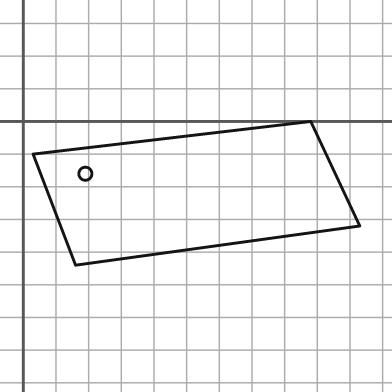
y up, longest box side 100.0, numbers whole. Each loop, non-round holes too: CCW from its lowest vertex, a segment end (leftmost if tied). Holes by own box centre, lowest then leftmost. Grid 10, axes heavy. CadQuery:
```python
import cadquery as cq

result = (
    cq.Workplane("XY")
    .moveTo(16.0, -44.0)
    .lineTo(103.0, -32.0)
    .lineTo(88.0, 0.0)
    .lineTo(3.0, -10.0)
    .close()
    .moveTo(19.0, -16.0)
    .circle(2.0)
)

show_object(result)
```